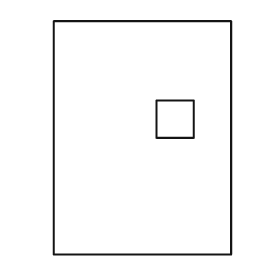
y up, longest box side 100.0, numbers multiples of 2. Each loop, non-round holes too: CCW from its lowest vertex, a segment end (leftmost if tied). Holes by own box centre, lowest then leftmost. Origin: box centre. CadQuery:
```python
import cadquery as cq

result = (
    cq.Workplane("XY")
    .moveTo(-38.0, -50.0)
    .lineTo(38.0, -50.0)
    .lineTo(38.0, 50.0)
    .lineTo(-38.0, 50.0)
    .close()
    .moveTo(6.0, 0.0)
    .lineTo(22.0, 0.0)
    .lineTo(22.0, 16.0)
    .lineTo(6.0, 16.0)
    .close()
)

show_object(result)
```